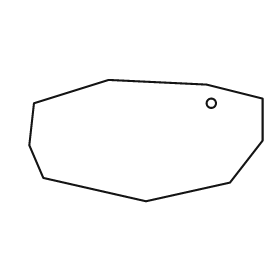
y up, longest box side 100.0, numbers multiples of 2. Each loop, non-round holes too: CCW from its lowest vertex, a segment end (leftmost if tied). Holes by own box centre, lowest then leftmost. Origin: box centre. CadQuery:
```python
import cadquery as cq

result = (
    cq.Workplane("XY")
    .moveTo(0.0, -26.0)
    .lineTo(36.0, -18.0)
    .lineTo(50.0, 0.0)
    .lineTo(50.0, 18.0)
    .lineTo(26.0, 24.0)
    .lineTo(-16.0, 26.0)
    .lineTo(-48.0, 16.0)
    .lineTo(-50.0, -2.0)
    .lineTo(-44.0, -16.0)
    .close()
    .moveTo(28.0, 16.0)
    .circle(2.0)
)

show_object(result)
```